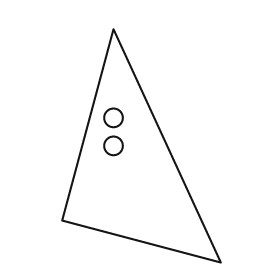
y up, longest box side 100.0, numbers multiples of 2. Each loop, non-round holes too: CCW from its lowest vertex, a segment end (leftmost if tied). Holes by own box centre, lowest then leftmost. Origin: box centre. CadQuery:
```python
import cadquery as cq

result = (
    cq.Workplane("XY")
    .moveTo(34.0, -50.0)
    .lineTo(-12.0, 50.0)
    .lineTo(-34.0, -32.0)
    .close()
    .moveTo(-12.0, 0.0)
    .circle(4.0)
    .moveTo(-12.0, 12.0)
    .circle(4.0)
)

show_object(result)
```